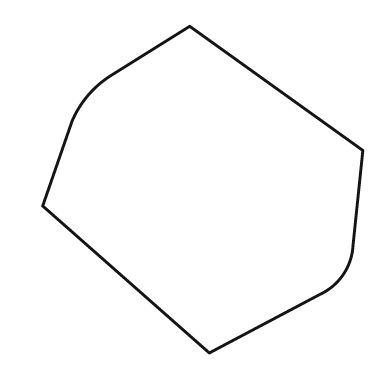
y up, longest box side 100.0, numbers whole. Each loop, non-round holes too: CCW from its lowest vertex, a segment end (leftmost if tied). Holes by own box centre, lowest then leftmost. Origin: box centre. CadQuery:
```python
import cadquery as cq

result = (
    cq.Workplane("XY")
    .moveTo(2.0, -50.0)
    .lineTo(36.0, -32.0)
    .threePointArc((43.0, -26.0), (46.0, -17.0))
    .lineTo(49.0, 12.0)
    .lineTo(-4.0, 50.0)
    .lineTo(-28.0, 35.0)
    .threePointArc((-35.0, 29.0), (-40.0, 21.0))
    .lineTo(-49.0, -5.0)
    .close()
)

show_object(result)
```